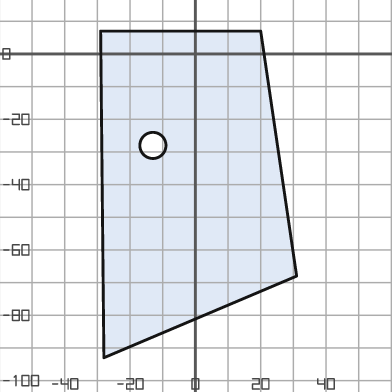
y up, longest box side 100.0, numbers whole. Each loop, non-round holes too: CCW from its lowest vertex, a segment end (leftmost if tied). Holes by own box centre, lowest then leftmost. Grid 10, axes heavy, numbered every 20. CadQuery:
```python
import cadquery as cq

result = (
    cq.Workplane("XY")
    .moveTo(-28.0, -93.0)
    .lineTo(31.0, -68.0)
    .lineTo(20.0, 7.0)
    .lineTo(-29.0, 7.0)
    .close()
    .moveTo(-13.0, -28.0)
    .circle(4.0)
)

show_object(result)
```